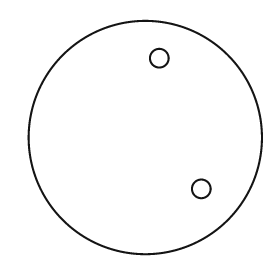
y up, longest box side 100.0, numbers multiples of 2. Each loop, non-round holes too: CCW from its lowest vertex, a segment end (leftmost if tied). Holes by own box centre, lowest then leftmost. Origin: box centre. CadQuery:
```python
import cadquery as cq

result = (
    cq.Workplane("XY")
    .moveTo(0.0, 0.0)
    .circle(50.0)
    .moveTo(24.0, -22.0)
    .circle(4.0)
    .moveTo(6.0, 34.0)
    .circle(4.0)
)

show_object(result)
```